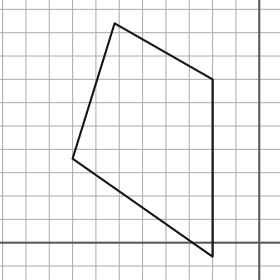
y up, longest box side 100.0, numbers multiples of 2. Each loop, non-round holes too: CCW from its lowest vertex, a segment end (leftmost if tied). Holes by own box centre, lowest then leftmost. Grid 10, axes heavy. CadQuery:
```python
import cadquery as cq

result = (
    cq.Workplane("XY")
    .moveTo(-20.0, -6.0)
    .lineTo(-20.0, 70.0)
    .lineTo(-62.0, 94.0)
    .lineTo(-80.0, 36.0)
    .close()
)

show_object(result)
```